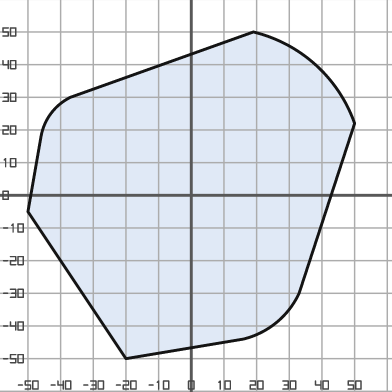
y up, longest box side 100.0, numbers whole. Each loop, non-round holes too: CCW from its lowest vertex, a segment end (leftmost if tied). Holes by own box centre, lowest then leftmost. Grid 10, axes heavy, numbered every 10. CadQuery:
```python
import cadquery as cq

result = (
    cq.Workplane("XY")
    .moveTo(-20.0, -50.0)
    .lineTo(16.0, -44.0)
    .threePointArc((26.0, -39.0), (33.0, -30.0))
    .lineTo(50.0, 22.0)
    .threePointArc((38.0, 40.0), (19.0, 50.0))
    .lineTo(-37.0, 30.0)
    .threePointArc((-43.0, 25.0), (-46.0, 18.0))
    .lineTo(-50.0, -5.0)
    .close()
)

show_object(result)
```